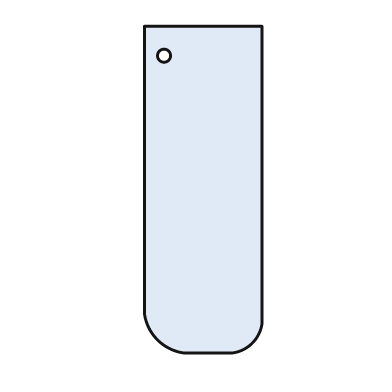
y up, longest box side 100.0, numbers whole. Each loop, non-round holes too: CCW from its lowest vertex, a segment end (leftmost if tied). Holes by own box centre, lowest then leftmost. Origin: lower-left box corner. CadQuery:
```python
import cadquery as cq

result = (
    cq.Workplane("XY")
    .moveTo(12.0, 0.0)
    .lineTo(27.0, 0.0)
    .threePointArc((33.0, 3.0), (36.0, 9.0))
    .lineTo(36.0, 100.0)
    .lineTo(0.0, 100.0)
    .lineTo(0.0, 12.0)
    .threePointArc((4.0, 4.0), (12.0, 0.0))
    .close()
    .moveTo(6.0, 91.0)
    .circle(2.0)
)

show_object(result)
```